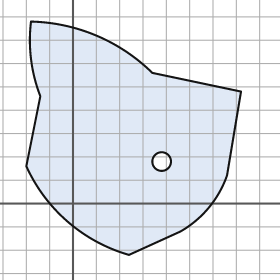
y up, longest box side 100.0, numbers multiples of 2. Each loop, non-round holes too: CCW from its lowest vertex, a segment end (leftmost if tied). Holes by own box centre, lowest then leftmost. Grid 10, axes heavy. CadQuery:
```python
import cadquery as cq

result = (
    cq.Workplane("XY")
    .moveTo(24.0, -22.0)
    .lineTo(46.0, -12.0)
    .threePointArc((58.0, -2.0), (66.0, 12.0))
    .lineTo(72.0, 48.0)
    .lineTo(34.0, 56.0)
    .threePointArc((10.0, 72.0), (-18.0, 78.0))
    .threePointArc((-18.0, 62.0), (-14.0, 46.0))
    .lineTo(-20.0, 16.0)
    .threePointArc((-2.0, -8.0), (24.0, -22.0))
    .close()
    .moveTo(38.0, 18.0)
    .circle(4.0)
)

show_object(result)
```